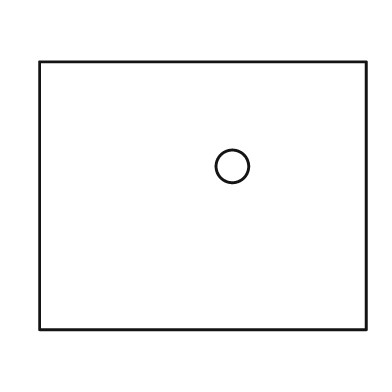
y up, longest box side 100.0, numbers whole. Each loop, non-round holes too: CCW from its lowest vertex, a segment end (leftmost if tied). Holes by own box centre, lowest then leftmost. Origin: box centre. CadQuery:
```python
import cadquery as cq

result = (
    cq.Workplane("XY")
    .moveTo(-50.0, -41.0)
    .lineTo(50.0, -41.0)
    .lineTo(50.0, 41.0)
    .lineTo(-50.0, 41.0)
    .close()
    .moveTo(9.0, 9.0)
    .circle(5.0)
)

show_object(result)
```